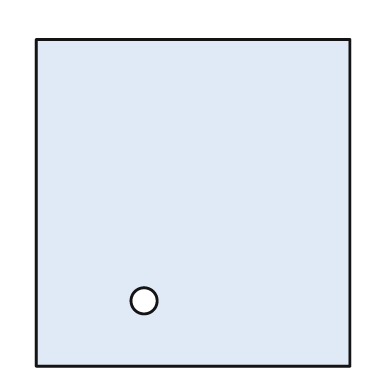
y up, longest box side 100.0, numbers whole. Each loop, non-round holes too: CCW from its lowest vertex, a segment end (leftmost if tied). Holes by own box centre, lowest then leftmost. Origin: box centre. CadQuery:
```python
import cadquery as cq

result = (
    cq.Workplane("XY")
    .moveTo(-48.0, -50.0)
    .lineTo(48.0, -50.0)
    .lineTo(48.0, 50.0)
    .lineTo(-48.0, 50.0)
    .close()
    .moveTo(-15.0, -30.0)
    .circle(4.0)
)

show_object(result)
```